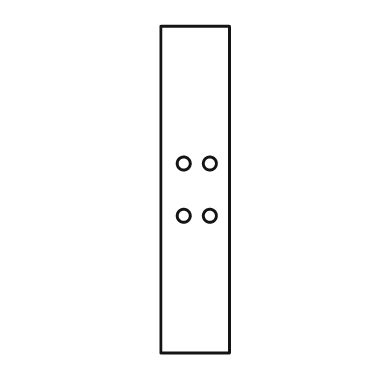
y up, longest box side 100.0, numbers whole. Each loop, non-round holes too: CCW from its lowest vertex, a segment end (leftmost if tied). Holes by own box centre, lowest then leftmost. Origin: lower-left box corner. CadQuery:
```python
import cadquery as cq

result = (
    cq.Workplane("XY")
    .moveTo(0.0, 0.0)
    .lineTo(21.0, 0.0)
    .lineTo(21.0, 100.0)
    .lineTo(0.0, 100.0)
    .close()
    .moveTo(7.0, 42.0)
    .circle(2.0)
    .moveTo(15.0, 42.0)
    .circle(2.0)
    .moveTo(7.0, 58.0)
    .circle(2.0)
    .moveTo(15.0, 58.0)
    .circle(2.0)
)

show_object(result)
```